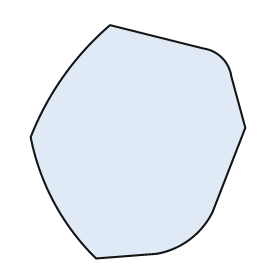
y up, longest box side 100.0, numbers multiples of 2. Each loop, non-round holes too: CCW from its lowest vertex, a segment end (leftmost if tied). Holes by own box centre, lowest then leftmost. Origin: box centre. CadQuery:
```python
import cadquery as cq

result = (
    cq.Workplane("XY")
    .moveTo(-18.0, -50.0)
    .lineTo(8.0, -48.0)
    .threePointArc((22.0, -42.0), (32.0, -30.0))
    .lineTo(46.0, 6.0)
    .lineTo(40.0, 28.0)
    .threePointArc((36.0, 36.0), (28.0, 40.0))
    .lineTo(-12.0, 50.0)
    .threePointArc((-32.0, 28.0), (-46.0, 2.0))
    .threePointArc((-36.0, -26.0), (-18.0, -50.0))
    .close()
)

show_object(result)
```